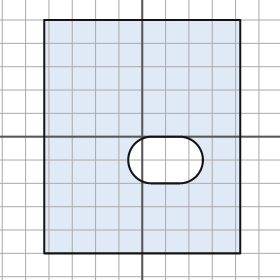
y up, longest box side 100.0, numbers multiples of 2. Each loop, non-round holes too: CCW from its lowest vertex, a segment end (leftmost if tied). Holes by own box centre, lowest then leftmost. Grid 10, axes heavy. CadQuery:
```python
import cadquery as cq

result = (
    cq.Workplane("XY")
    .moveTo(-42.0, -50.0)
    .lineTo(42.0, -50.0)
    .lineTo(42.0, 50.0)
    .lineTo(-42.0, 50.0)
    .close()
    .moveTo(4.0, -20.0)
    .lineTo(16.0, -20.0)
    .threePointArc((26.0, -10.0), (16.0, 0.0))
    .lineTo(4.0, 0.0)
    .threePointArc((-6.0, -10.0), (4.0, -20.0))
    .close()
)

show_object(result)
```